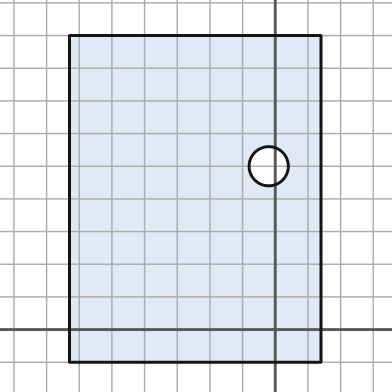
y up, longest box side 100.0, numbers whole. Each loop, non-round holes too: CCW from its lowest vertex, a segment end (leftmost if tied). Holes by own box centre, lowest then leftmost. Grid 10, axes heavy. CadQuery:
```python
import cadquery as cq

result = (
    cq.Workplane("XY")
    .moveTo(-63.0, -10.0)
    .lineTo(14.0, -10.0)
    .lineTo(14.0, 90.0)
    .lineTo(-63.0, 90.0)
    .close()
    .moveTo(-2.0, 50.0)
    .circle(6.0)
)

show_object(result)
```